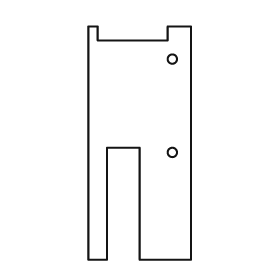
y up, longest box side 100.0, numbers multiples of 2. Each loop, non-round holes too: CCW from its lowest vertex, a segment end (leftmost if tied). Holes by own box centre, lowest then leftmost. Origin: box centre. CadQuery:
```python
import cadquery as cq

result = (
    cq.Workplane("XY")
    .moveTo(-22.0, -50.0)
    .lineTo(-14.0, -50.0)
    .lineTo(-14.0, -2.0)
    .lineTo(0.0, -2.0)
    .lineTo(0.0, -50.0)
    .lineTo(22.0, -50.0)
    .lineTo(22.0, 50.0)
    .lineTo(12.0, 50.0)
    .lineTo(12.0, 44.0)
    .lineTo(-18.0, 44.0)
    .lineTo(-18.0, 50.0)
    .lineTo(-22.0, 50.0)
    .close()
    .moveTo(14.0, -4.0)
    .circle(2.0)
    .moveTo(14.0, 36.0)
    .circle(2.0)
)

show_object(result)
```